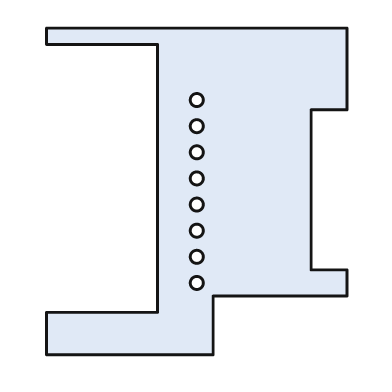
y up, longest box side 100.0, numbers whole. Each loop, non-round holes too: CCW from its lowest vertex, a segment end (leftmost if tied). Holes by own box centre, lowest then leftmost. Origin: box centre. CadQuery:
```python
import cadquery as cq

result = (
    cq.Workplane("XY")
    .moveTo(-46.0, -50.0)
    .lineTo(5.0, -50.0)
    .lineTo(5.0, -32.0)
    .lineTo(46.0, -32.0)
    .lineTo(46.0, -24.0)
    .lineTo(35.0, -24.0)
    .lineTo(35.0, 25.0)
    .lineTo(46.0, 25.0)
    .lineTo(46.0, 50.0)
    .lineTo(-46.0, 50.0)
    .lineTo(-46.0, 45.0)
    .lineTo(-12.0, 45.0)
    .lineTo(-12.0, -37.0)
    .lineTo(-46.0, -37.0)
    .close()
    .moveTo(0.0, -28.0)
    .circle(2.0)
    .moveTo(0.0, -20.0)
    .circle(2.0)
    .moveTo(0.0, -12.0)
    .circle(2.0)
    .moveTo(0.0, -4.0)
    .circle(2.0)
    .moveTo(0.0, 4.0)
    .circle(2.0)
    .moveTo(0.0, 12.0)
    .circle(2.0)
    .moveTo(0.0, 20.0)
    .circle(2.0)
    .moveTo(0.0, 28.0)
    .circle(2.0)
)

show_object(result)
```